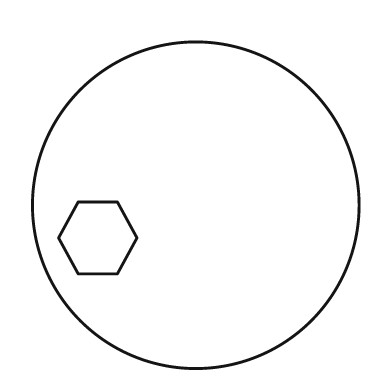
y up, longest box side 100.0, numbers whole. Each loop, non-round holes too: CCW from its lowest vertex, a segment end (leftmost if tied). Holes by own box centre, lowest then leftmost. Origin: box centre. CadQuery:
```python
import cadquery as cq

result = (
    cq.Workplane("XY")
    .moveTo(0.0, 0.0)
    .circle(50.0)
    .moveTo(-36.0, -21.0)
    .lineTo(-24.0, -21.0)
    .lineTo(-18.0, -10.0)
    .lineTo(-24.0, 1.0)
    .lineTo(-36.0, 1.0)
    .lineTo(-42.0, -10.0)
    .close()
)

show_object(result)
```